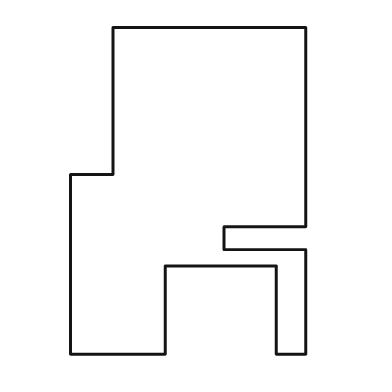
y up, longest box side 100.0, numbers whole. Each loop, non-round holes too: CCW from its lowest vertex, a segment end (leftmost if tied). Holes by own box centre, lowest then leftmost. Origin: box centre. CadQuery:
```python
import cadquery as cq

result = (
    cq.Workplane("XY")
    .moveTo(-36.0, -50.0)
    .lineTo(-7.0, -50.0)
    .lineTo(-7.0, -23.0)
    .lineTo(27.0, -23.0)
    .lineTo(27.0, -50.0)
    .lineTo(36.0, -50.0)
    .lineTo(36.0, -18.0)
    .lineTo(11.0, -18.0)
    .lineTo(11.0, -11.0)
    .lineTo(36.0, -11.0)
    .lineTo(36.0, 50.0)
    .lineTo(-23.0, 50.0)
    .lineTo(-23.0, 5.0)
    .lineTo(-36.0, 5.0)
    .close()
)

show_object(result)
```